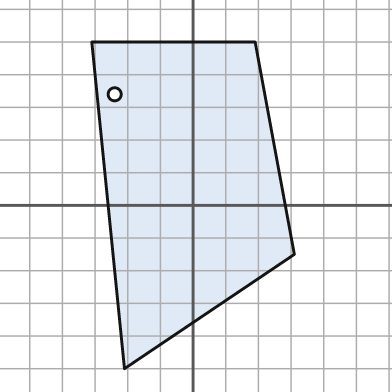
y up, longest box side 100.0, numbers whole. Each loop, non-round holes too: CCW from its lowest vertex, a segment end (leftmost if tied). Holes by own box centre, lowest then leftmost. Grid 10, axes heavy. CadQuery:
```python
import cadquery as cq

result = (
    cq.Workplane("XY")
    .moveTo(-21.0, -50.0)
    .lineTo(31.0, -15.0)
    .lineTo(19.0, 50.0)
    .lineTo(-31.0, 50.0)
    .close()
    .moveTo(-24.0, 34.0)
    .circle(2.0)
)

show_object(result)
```